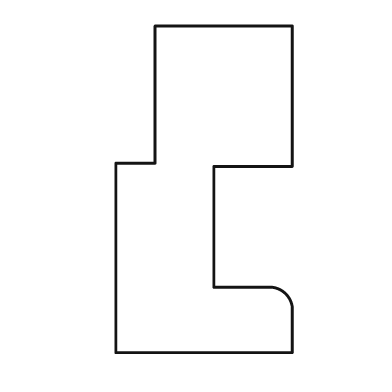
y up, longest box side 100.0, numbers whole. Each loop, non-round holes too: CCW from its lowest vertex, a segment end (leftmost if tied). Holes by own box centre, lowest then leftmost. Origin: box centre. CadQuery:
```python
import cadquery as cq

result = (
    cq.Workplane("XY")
    .moveTo(-27.0, -50.0)
    .lineTo(27.0, -50.0)
    .lineTo(27.0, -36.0)
    .threePointArc((25.0, -32.0), (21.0, -30.0))
    .lineTo(3.0, -30.0)
    .lineTo(3.0, 7.0)
    .lineTo(27.0, 7.0)
    .lineTo(27.0, 50.0)
    .lineTo(-15.0, 50.0)
    .lineTo(-15.0, 8.0)
    .lineTo(-27.0, 8.0)
    .close()
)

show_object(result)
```